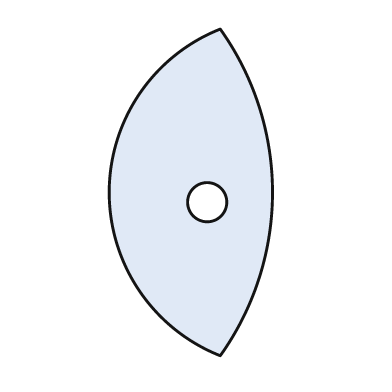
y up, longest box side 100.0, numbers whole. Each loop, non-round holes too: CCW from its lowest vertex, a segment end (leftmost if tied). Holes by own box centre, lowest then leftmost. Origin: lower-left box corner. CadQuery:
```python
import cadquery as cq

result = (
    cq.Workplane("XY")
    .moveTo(34.0, 0.0)
    .threePointArc((50.0, 50.0), (34.0, 100.0))
    .threePointArc((0.0, 50.0), (34.0, 0.0))
    .close()
    .moveTo(30.0, 47.0)
    .circle(6.0)
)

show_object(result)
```